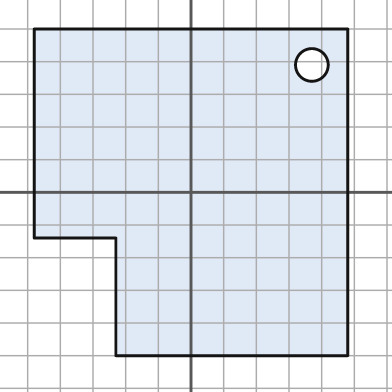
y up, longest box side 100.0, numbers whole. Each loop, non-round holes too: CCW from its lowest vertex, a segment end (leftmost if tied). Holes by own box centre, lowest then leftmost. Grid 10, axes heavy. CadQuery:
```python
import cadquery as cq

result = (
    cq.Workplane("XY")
    .moveTo(-23.0, -50.0)
    .lineTo(48.0, -50.0)
    .lineTo(48.0, 50.0)
    .lineTo(-48.0, 50.0)
    .lineTo(-48.0, -14.0)
    .lineTo(-23.0, -14.0)
    .close()
    .moveTo(37.0, 39.0)
    .circle(5.0)
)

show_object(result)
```